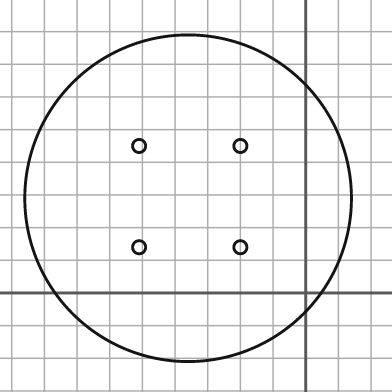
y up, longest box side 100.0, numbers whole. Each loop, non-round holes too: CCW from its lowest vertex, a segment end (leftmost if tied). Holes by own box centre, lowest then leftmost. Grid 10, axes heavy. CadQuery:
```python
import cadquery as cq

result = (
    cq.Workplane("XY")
    .moveTo(-36.0, 29.0)
    .circle(50.0)
    .moveTo(-51.0, 14.0)
    .circle(2.0)
    .moveTo(-20.0, 14.0)
    .circle(2.0)
    .moveTo(-51.0, 45.0)
    .circle(2.0)
    .moveTo(-20.0, 45.0)
    .circle(2.0)
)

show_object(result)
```